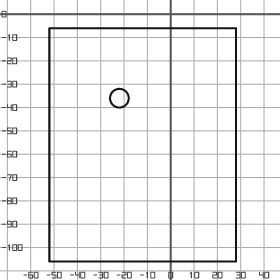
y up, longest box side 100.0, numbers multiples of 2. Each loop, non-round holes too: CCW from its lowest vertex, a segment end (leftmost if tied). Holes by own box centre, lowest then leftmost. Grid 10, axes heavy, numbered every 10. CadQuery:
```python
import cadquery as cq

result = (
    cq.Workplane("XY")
    .moveTo(-52.0, -106.0)
    .lineTo(28.0, -106.0)
    .lineTo(28.0, -6.0)
    .lineTo(-52.0, -6.0)
    .close()
    .moveTo(-22.0, -36.0)
    .circle(4.0)
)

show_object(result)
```